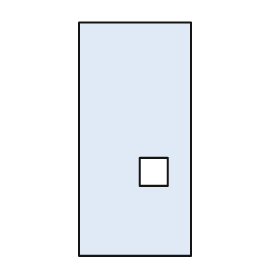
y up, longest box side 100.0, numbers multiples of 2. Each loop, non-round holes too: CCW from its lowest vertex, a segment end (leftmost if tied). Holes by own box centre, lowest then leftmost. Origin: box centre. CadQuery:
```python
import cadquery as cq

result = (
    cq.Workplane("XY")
    .moveTo(-24.0, -50.0)
    .lineTo(24.0, -50.0)
    .lineTo(24.0, 50.0)
    .lineTo(-24.0, 50.0)
    .close()
    .moveTo(2.0, -20.0)
    .lineTo(14.0, -20.0)
    .lineTo(14.0, -8.0)
    .lineTo(2.0, -8.0)
    .close()
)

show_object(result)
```